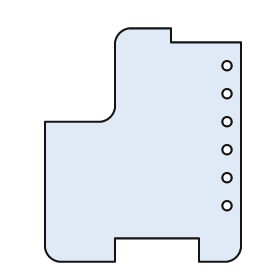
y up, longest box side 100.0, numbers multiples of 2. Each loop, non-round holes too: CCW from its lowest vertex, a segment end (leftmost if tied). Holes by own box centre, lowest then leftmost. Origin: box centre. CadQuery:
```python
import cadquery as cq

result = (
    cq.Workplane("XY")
    .moveTo(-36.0, -50.0)
    .lineTo(-12.0, -50.0)
    .lineTo(-12.0, -40.0)
    .lineTo(24.0, -40.0)
    .lineTo(24.0, -50.0)
    .lineTo(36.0, -50.0)
    .threePointArc((40.0, -48.0), (42.0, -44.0))
    .lineTo(42.0, 44.0)
    .lineTo(12.0, 44.0)
    .lineTo(12.0, 50.0)
    .lineTo(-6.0, 50.0)
    .threePointArc((-10.0, 48.0), (-12.0, 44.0))
    .lineTo(-12.0, 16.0)
    .threePointArc((-14.0, 12.0), (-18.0, 10.0))
    .lineTo(-42.0, 10.0)
    .lineTo(-42.0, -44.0)
    .threePointArc((-40.0, -48.0), (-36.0, -50.0))
    .close()
    .moveTo(36.0, -26.0)
    .circle(2.0)
    .moveTo(36.0, -14.0)
    .circle(2.0)
    .moveTo(36.0, -2.0)
    .circle(2.0)
    .moveTo(36.0, 10.0)
    .circle(2.0)
    .moveTo(36.0, 22.0)
    .circle(2.0)
    .moveTo(36.0, 34.0)
    .circle(2.0)
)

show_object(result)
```